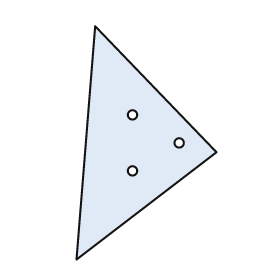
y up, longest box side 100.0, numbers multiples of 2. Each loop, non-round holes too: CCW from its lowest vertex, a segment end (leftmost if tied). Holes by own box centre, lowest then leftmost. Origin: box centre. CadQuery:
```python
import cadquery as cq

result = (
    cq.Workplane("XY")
    .moveTo(-30.0, -50.0)
    .lineTo(30.0, -4.0)
    .lineTo(-22.0, 50.0)
    .close()
    .moveTo(-6.0, -12.0)
    .circle(2.0)
    .moveTo(14.0, 0.0)
    .circle(2.0)
    .moveTo(-6.0, 12.0)
    .circle(2.0)
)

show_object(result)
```